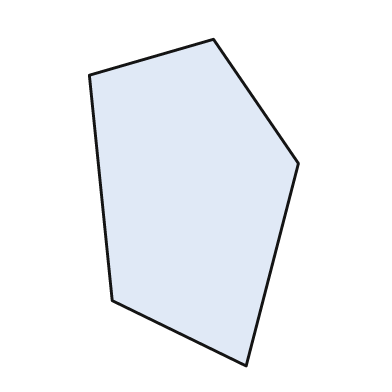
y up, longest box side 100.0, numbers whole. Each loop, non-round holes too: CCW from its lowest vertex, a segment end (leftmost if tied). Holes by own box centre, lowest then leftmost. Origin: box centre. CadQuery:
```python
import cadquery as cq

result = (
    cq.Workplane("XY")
    .moveTo(16.0, -50.0)
    .lineTo(32.0, 12.0)
    .lineTo(6.0, 50.0)
    .lineTo(-32.0, 39.0)
    .lineTo(-25.0, -30.0)
    .close()
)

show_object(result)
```